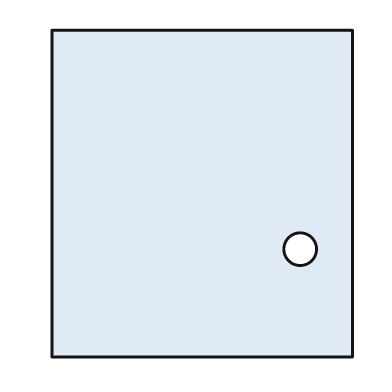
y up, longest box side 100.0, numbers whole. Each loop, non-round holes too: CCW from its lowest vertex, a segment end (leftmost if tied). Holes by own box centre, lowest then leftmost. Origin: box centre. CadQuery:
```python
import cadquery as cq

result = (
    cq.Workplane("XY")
    .moveTo(-46.0, -50.0)
    .lineTo(46.0, -50.0)
    .lineTo(46.0, 50.0)
    .lineTo(-46.0, 50.0)
    .close()
    .moveTo(30.0, -17.0)
    .circle(5.0)
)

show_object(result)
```